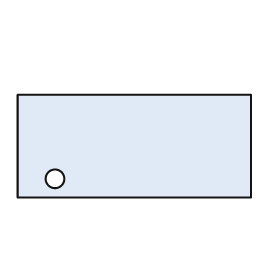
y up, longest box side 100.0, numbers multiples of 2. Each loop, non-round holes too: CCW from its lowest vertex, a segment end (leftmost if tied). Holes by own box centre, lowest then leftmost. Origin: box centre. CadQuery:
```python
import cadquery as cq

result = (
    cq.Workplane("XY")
    .moveTo(-50.0, -22.0)
    .lineTo(50.0, -22.0)
    .lineTo(50.0, 22.0)
    .lineTo(-50.0, 22.0)
    .close()
    .moveTo(-34.0, -14.0)
    .circle(4.0)
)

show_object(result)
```